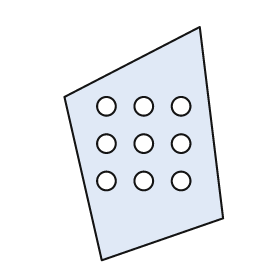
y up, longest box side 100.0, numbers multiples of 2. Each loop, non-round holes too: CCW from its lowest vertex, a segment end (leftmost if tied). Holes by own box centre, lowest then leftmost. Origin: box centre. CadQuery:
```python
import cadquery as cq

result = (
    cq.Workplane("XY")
    .moveTo(-18.0, -50.0)
    .lineTo(34.0, -32.0)
    .lineTo(24.0, 50.0)
    .lineTo(-34.0, 20.0)
    .close()
    .moveTo(-16.0, -16.0)
    .circle(4.0)
    .moveTo(0.0, -16.0)
    .circle(4.0)
    .moveTo(16.0, -16.0)
    .circle(4.0)
    .moveTo(-16.0, 0.0)
    .circle(4.0)
    .moveTo(0.0, 0.0)
    .circle(4.0)
    .moveTo(16.0, 0.0)
    .circle(4.0)
    .moveTo(-16.0, 16.0)
    .circle(4.0)
    .moveTo(0.0, 16.0)
    .circle(4.0)
    .moveTo(16.0, 16.0)
    .circle(4.0)
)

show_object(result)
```